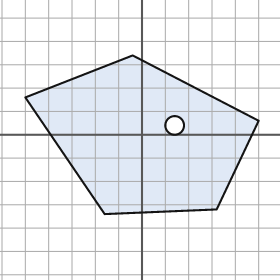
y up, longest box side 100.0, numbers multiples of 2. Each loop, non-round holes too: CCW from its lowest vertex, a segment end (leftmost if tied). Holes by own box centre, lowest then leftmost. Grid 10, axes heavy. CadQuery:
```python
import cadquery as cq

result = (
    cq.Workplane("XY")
    .moveTo(-16.0, -34.0)
    .lineTo(32.0, -32.0)
    .lineTo(50.0, 6.0)
    .lineTo(-4.0, 34.0)
    .lineTo(-50.0, 16.0)
    .close()
    .moveTo(14.0, 4.0)
    .circle(4.0)
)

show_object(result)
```